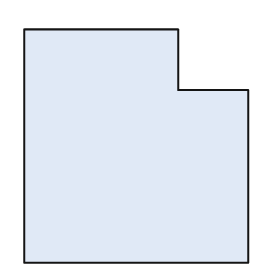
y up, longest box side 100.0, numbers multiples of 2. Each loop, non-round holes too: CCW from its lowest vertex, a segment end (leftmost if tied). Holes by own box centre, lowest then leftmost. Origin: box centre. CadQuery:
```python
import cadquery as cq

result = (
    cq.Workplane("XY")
    .moveTo(-48.0, -50.0)
    .lineTo(48.0, -50.0)
    .lineTo(48.0, 24.0)
    .lineTo(18.0, 24.0)
    .lineTo(18.0, 50.0)
    .lineTo(-48.0, 50.0)
    .close()
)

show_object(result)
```